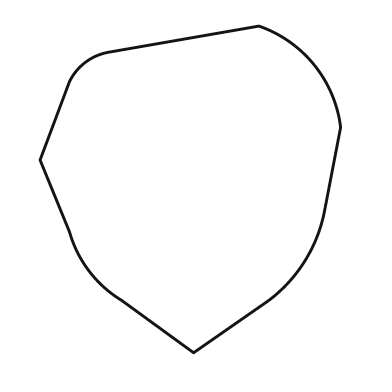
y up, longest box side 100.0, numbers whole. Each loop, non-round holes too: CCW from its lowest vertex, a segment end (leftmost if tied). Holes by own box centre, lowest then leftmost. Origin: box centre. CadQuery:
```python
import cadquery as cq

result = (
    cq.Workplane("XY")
    .moveTo(1.0, -50.0)
    .lineTo(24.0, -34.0)
    .threePointArc((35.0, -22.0), (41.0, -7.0))
    .lineTo(46.0, 19.0)
    .threePointArc((38.0, 38.0), (21.0, 50.0))
    .lineTo(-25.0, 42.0)
    .threePointArc((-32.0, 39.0), (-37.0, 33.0))
    .lineTo(-46.0, 9.0)
    .lineTo(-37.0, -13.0)
    .threePointArc((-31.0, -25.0), (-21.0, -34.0))
    .close()
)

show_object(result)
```